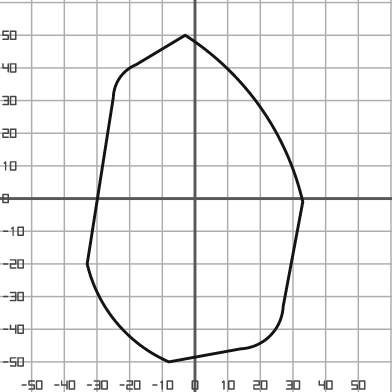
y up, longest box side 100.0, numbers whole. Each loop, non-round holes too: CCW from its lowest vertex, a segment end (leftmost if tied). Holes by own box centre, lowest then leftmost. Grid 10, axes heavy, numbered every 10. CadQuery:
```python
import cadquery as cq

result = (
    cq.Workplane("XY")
    .moveTo(-8.0, -50.0)
    .lineTo(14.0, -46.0)
    .threePointArc((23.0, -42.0), (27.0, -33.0))
    .lineTo(33.0, -1.0)
    .threePointArc((20.0, 28.0), (-3.0, 50.0))
    .lineTo(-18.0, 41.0)
    .threePointArc((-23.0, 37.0), (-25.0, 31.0))
    .lineTo(-33.0, -20.0)
    .threePointArc((-24.0, -38.0), (-8.0, -50.0))
    .close()
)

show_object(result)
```